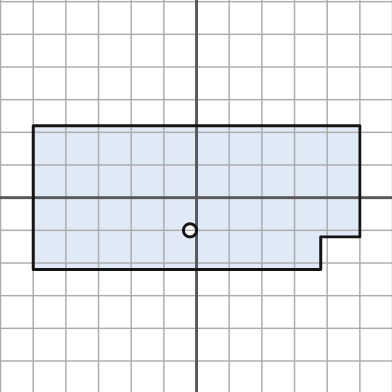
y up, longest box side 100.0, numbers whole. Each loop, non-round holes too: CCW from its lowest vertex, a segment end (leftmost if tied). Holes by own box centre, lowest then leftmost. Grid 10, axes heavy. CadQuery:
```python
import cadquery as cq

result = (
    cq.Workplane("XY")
    .moveTo(-50.0, -22.0)
    .lineTo(38.0, -22.0)
    .lineTo(38.0, -12.0)
    .lineTo(50.0, -12.0)
    .lineTo(50.0, 22.0)
    .lineTo(-50.0, 22.0)
    .close()
    .moveTo(-2.0, -10.0)
    .circle(2.0)
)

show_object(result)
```